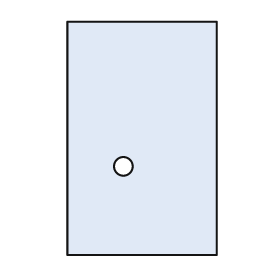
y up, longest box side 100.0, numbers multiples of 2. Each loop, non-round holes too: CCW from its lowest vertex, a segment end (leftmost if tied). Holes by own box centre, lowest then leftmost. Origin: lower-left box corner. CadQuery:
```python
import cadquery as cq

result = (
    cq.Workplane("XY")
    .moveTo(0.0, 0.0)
    .lineTo(64.0, 0.0)
    .lineTo(64.0, 100.0)
    .lineTo(0.0, 100.0)
    .close()
    .moveTo(24.0, 38.0)
    .circle(4.0)
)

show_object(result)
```